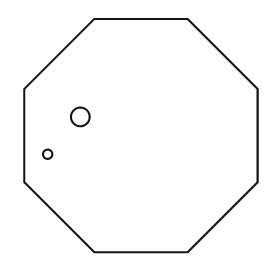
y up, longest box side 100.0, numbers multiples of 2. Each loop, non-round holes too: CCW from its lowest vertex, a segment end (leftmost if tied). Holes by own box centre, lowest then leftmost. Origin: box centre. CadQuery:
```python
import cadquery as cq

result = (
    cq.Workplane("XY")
    .moveTo(-20.0, -50.0)
    .lineTo(20.0, -50.0)
    .lineTo(50.0, -20.0)
    .lineTo(50.0, 20.0)
    .lineTo(20.0, 50.0)
    .lineTo(-20.0, 50.0)
    .lineTo(-50.0, 20.0)
    .lineTo(-50.0, -20.0)
    .close()
    .moveTo(-40.0, -8.0)
    .circle(2.0)
    .moveTo(-26.0, 8.0)
    .circle(4.0)
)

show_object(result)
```